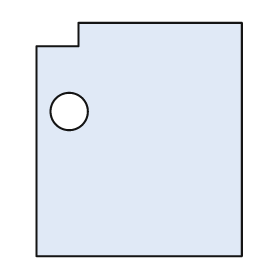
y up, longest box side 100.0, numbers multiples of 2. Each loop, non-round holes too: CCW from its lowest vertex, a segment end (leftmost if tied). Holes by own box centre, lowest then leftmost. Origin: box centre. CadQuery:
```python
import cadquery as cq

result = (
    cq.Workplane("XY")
    .moveTo(-44.0, -50.0)
    .lineTo(44.0, -50.0)
    .lineTo(44.0, 50.0)
    .lineTo(-26.0, 50.0)
    .lineTo(-26.0, 40.0)
    .lineTo(-44.0, 40.0)
    .close()
    .moveTo(-30.0, 12.0)
    .circle(8.0)
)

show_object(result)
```